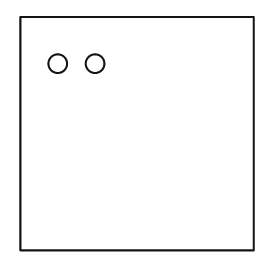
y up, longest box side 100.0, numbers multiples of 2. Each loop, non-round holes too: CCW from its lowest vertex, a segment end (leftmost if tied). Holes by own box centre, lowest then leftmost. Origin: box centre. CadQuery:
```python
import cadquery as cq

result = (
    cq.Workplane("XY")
    .moveTo(-50.0, -50.0)
    .lineTo(50.0, -50.0)
    .lineTo(50.0, 50.0)
    .lineTo(-50.0, 50.0)
    .close()
    .moveTo(-34.0, 30.0)
    .circle(4.0)
    .moveTo(-18.0, 30.0)
    .circle(4.0)
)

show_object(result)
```